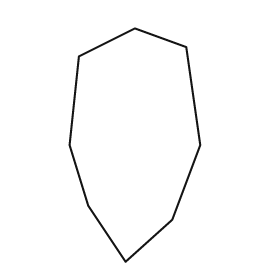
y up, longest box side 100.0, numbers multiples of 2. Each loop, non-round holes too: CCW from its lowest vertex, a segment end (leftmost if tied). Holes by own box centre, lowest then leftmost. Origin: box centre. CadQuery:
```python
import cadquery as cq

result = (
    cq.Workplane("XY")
    .moveTo(-4.0, -50.0)
    .lineTo(16.0, -32.0)
    .lineTo(28.0, 0.0)
    .lineTo(22.0, 42.0)
    .lineTo(0.0, 50.0)
    .lineTo(-24.0, 38.0)
    .lineTo(-28.0, 0.0)
    .lineTo(-20.0, -26.0)
    .close()
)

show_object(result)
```